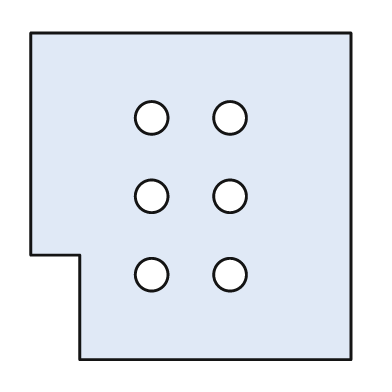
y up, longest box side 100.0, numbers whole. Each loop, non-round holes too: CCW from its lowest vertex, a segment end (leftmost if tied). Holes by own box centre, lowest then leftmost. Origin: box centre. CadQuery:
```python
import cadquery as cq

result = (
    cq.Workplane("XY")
    .moveTo(-34.0, -50.0)
    .lineTo(49.0, -50.0)
    .lineTo(49.0, 50.0)
    .lineTo(-49.0, 50.0)
    .lineTo(-49.0, -18.0)
    .lineTo(-34.0, -18.0)
    .close()
    .moveTo(-12.0, -24.0)
    .circle(5.0)
    .moveTo(12.0, -24.0)
    .circle(5.0)
    .moveTo(-12.0, 0.0)
    .circle(5.0)
    .moveTo(12.0, 0.0)
    .circle(5.0)
    .moveTo(-12.0, 24.0)
    .circle(5.0)
    .moveTo(12.0, 24.0)
    .circle(5.0)
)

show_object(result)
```